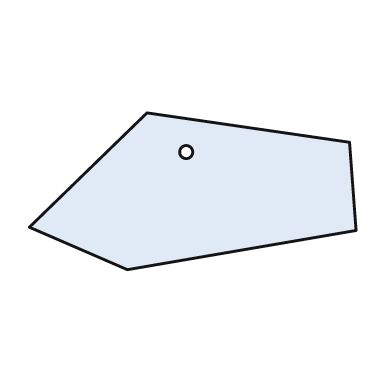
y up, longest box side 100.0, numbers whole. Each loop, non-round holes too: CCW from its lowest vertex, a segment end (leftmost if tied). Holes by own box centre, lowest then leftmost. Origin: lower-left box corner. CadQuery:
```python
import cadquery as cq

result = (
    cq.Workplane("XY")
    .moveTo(30.0, 0.0)
    .lineTo(100.0, 12.0)
    .lineTo(98.0, 39.0)
    .lineTo(36.0, 48.0)
    .lineTo(0.0, 13.0)
    .close()
    .moveTo(48.0, 36.0)
    .circle(2.0)
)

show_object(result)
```